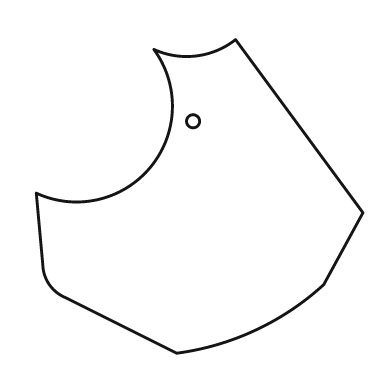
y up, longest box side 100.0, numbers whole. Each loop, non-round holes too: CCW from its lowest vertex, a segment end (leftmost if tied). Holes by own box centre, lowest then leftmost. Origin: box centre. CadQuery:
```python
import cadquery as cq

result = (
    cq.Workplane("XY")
    .moveTo(-7.0, -48.0)
    .threePointArc((17.0, -41.0), (38.0, -27.0))
    .lineTo(50.0, -5.0)
    .lineTo(11.0, 48.0)
    .threePointArc((-1.0, 43.0), (-14.0, 45.0))
    .threePointArc((-15.0, 9.0), (-50.0, 1.0))
    .lineTo(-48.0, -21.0)
    .threePointArc((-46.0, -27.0), (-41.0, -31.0))
    .close()
    .moveTo(-2.0, 23.0)
    .circle(2.0)
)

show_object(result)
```